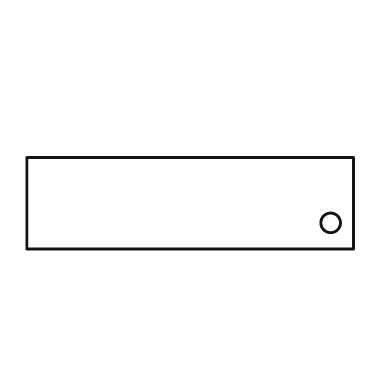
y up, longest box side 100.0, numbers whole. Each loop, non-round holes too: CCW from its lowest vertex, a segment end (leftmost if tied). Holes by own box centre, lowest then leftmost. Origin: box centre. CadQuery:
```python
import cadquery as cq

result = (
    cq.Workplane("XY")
    .moveTo(-50.0, -14.0)
    .lineTo(50.0, -14.0)
    .lineTo(50.0, 14.0)
    .lineTo(-50.0, 14.0)
    .close()
    .moveTo(43.0, -6.0)
    .circle(3.0)
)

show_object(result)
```